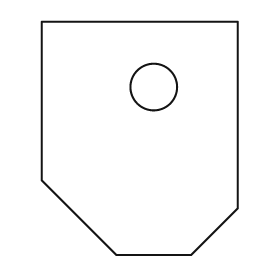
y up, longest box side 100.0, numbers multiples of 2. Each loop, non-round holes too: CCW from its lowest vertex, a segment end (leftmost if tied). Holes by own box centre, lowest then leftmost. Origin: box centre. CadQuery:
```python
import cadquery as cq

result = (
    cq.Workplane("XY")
    .moveTo(-10.0, -50.0)
    .lineTo(22.0, -50.0)
    .lineTo(42.0, -30.0)
    .lineTo(42.0, 50.0)
    .lineTo(-42.0, 50.0)
    .lineTo(-42.0, -18.0)
    .close()
    .moveTo(6.0, 22.0)
    .circle(10.0)
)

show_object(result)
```